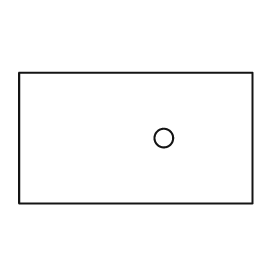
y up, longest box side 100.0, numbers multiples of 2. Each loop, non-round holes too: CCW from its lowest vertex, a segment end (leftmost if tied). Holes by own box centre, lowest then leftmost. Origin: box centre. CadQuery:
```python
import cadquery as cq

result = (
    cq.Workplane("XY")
    .moveTo(-50.0, -28.0)
    .lineTo(50.0, -28.0)
    .lineTo(50.0, 28.0)
    .lineTo(-50.0, 28.0)
    .close()
    .moveTo(12.0, 0.0)
    .circle(4.0)
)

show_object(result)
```